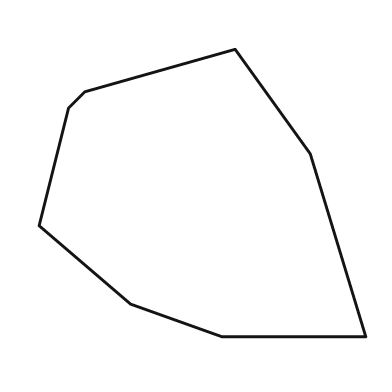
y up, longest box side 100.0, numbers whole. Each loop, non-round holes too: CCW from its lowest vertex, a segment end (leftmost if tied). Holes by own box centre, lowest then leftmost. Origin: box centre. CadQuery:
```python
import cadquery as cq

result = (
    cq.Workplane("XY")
    .moveTo(6.0, -44.0)
    .lineTo(50.0, -44.0)
    .lineTo(33.0, 12.0)
    .lineTo(10.0, 44.0)
    .lineTo(-36.0, 31.0)
    .lineTo(-41.0, 26.0)
    .lineTo(-50.0, -10.0)
    .lineTo(-22.0, -34.0)
    .close()
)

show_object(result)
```